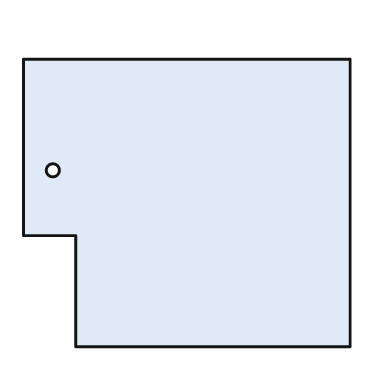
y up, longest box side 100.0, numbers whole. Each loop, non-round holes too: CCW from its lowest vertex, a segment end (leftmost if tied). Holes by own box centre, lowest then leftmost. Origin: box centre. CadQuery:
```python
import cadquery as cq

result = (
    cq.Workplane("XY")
    .moveTo(-34.0, -44.0)
    .lineTo(50.0, -44.0)
    .lineTo(50.0, 44.0)
    .lineTo(-50.0, 44.0)
    .lineTo(-50.0, -10.0)
    .lineTo(-34.0, -10.0)
    .close()
    .moveTo(-41.0, 10.0)
    .circle(2.0)
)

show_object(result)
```